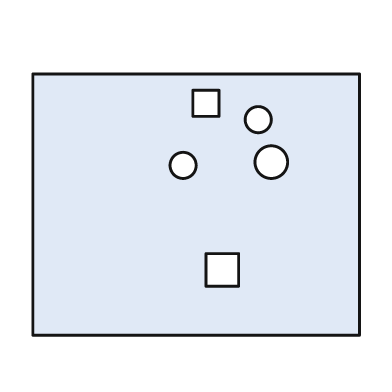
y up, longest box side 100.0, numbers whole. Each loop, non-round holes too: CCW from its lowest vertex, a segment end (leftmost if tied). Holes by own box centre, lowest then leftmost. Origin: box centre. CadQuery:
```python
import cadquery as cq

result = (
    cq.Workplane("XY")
    .moveTo(-50.0, -40.0)
    .lineTo(50.0, -40.0)
    .lineTo(50.0, 40.0)
    .lineTo(-50.0, 40.0)
    .close()
    .moveTo(3.0, -25.0)
    .lineTo(13.0, -25.0)
    .lineTo(13.0, -15.0)
    .lineTo(3.0, -15.0)
    .close()
    .moveTo(-4.0, 12.0)
    .circle(4.0)
    .moveTo(23.0, 13.0)
    .circle(5.0)
    .moveTo(19.0, 26.0)
    .circle(4.0)
    .moveTo(-1.0, 27.0)
    .lineTo(7.0, 27.0)
    .lineTo(7.0, 35.0)
    .lineTo(-1.0, 35.0)
    .close()
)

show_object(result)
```